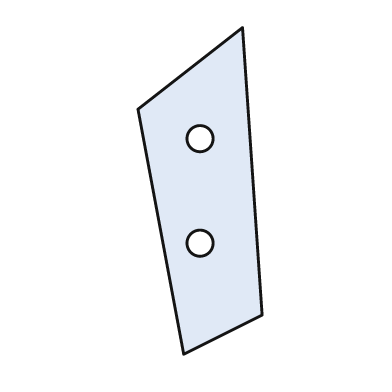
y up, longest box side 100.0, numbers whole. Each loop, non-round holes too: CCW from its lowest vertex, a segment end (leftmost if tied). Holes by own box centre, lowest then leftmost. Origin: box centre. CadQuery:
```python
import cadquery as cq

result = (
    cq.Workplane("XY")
    .moveTo(-5.0, -50.0)
    .lineTo(19.0, -38.0)
    .lineTo(13.0, 50.0)
    .lineTo(-19.0, 25.0)
    .close()
    .moveTo(0.0, -16.0)
    .circle(4.0)
    .moveTo(0.0, 16.0)
    .circle(4.0)
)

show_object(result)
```